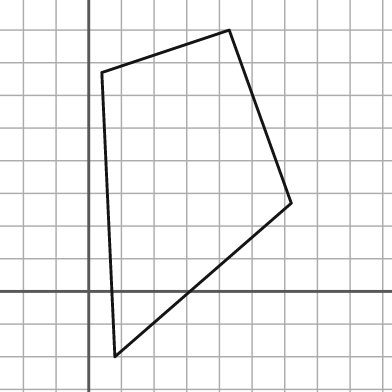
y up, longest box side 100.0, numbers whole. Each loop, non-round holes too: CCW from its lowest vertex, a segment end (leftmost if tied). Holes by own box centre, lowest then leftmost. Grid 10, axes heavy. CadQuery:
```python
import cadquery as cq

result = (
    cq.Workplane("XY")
    .moveTo(8.0, -20.0)
    .lineTo(62.0, 27.0)
    .lineTo(43.0, 80.0)
    .lineTo(4.0, 67.0)
    .close()
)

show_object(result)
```